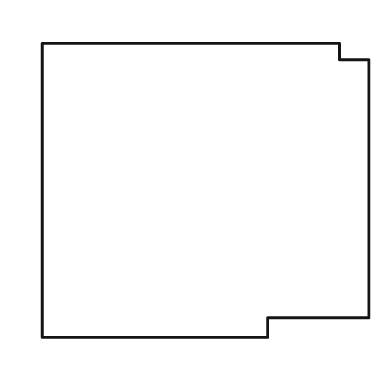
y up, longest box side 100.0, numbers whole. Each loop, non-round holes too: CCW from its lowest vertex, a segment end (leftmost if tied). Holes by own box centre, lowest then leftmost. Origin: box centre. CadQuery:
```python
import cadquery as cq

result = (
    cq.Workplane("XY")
    .moveTo(-50.0, -45.0)
    .lineTo(19.0, -45.0)
    .lineTo(19.0, -39.0)
    .lineTo(50.0, -39.0)
    .lineTo(50.0, 40.0)
    .lineTo(41.0, 40.0)
    .lineTo(41.0, 45.0)
    .lineTo(-50.0, 45.0)
    .close()
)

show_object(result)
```